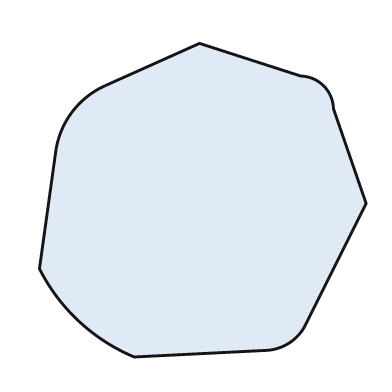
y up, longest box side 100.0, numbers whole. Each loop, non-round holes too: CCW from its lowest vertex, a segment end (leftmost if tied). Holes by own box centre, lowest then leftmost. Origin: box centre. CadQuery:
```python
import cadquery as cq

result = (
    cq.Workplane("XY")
    .moveTo(-21.0, -48.0)
    .lineTo(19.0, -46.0)
    .threePointArc((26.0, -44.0), (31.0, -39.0))
    .lineTo(50.0, -1.0)
    .lineTo(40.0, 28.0)
    .threePointArc((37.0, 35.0), (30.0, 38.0))
    .lineTo(-1.0, 48.0)
    .lineTo(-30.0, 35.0)
    .threePointArc((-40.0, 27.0), (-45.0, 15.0))
    .lineTo(-50.0, -21.0)
    .threePointArc((-38.0, -37.0), (-21.0, -48.0))
    .close()
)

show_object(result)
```